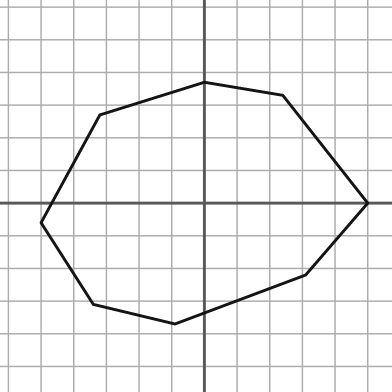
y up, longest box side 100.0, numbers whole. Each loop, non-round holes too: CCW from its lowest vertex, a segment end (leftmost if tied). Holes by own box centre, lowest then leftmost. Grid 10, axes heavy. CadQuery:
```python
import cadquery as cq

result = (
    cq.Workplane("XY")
    .moveTo(-9.0, -37.0)
    .lineTo(31.0, -22.0)
    .lineTo(50.0, 0.0)
    .lineTo(24.0, 33.0)
    .lineTo(0.0, 37.0)
    .lineTo(-32.0, 27.0)
    .lineTo(-50.0, -6.0)
    .lineTo(-34.0, -31.0)
    .close()
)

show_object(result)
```